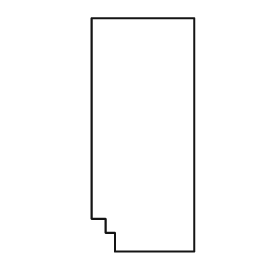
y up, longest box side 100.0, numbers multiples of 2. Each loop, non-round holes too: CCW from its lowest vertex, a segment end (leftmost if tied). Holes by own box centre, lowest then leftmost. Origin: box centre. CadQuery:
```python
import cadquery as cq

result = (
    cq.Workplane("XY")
    .moveTo(-12.0, -50.0)
    .lineTo(22.0, -50.0)
    .lineTo(22.0, 50.0)
    .lineTo(-22.0, 50.0)
    .lineTo(-22.0, -36.0)
    .lineTo(-16.0, -36.0)
    .lineTo(-16.0, -42.0)
    .lineTo(-12.0, -42.0)
    .close()
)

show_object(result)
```